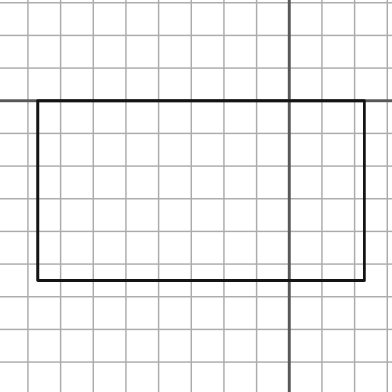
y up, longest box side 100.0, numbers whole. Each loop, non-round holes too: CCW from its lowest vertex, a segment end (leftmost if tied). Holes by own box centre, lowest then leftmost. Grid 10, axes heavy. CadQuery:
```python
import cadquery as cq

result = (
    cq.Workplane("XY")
    .moveTo(-77.0, -55.0)
    .lineTo(23.0, -55.0)
    .lineTo(23.0, 0.0)
    .lineTo(-77.0, 0.0)
    .close()
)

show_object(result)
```